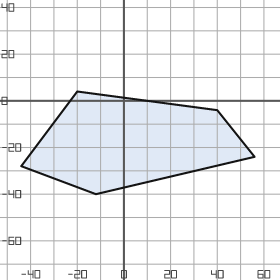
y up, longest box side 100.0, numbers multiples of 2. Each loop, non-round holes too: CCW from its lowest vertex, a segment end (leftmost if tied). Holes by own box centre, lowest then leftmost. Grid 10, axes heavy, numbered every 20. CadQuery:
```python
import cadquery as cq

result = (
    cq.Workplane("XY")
    .moveTo(-12.0, -40.0)
    .lineTo(56.0, -24.0)
    .lineTo(40.0, -4.0)
    .lineTo(-20.0, 4.0)
    .lineTo(-44.0, -28.0)
    .close()
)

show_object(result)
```